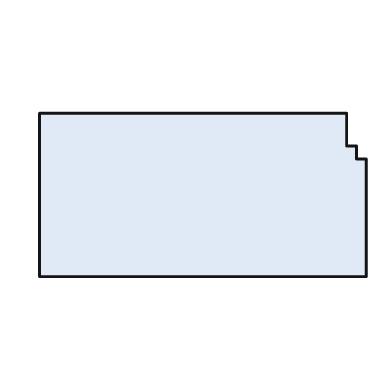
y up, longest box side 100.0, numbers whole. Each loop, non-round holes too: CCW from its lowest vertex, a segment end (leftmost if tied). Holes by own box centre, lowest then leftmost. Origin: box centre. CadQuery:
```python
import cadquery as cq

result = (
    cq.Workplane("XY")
    .moveTo(-50.0, -25.0)
    .lineTo(50.0, -25.0)
    .lineTo(50.0, 11.0)
    .lineTo(47.0, 11.0)
    .lineTo(47.0, 15.0)
    .lineTo(44.0, 15.0)
    .lineTo(44.0, 25.0)
    .lineTo(-50.0, 25.0)
    .close()
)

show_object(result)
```